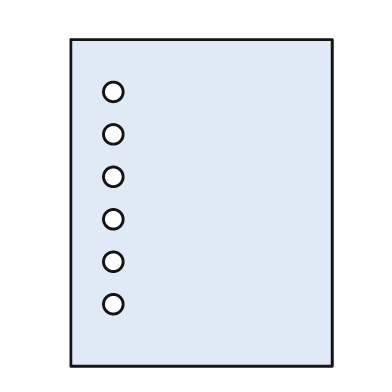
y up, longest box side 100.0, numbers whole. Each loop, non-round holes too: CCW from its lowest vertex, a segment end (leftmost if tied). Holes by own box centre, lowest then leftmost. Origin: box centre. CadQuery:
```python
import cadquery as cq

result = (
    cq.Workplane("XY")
    .moveTo(-40.0, -50.0)
    .lineTo(40.0, -50.0)
    .lineTo(40.0, 50.0)
    .lineTo(-40.0, 50.0)
    .close()
    .moveTo(-27.0, -31.0)
    .circle(3.0)
    .moveTo(-27.0, -18.0)
    .circle(3.0)
    .moveTo(-27.0, -5.0)
    .circle(3.0)
    .moveTo(-27.0, 8.0)
    .circle(3.0)
    .moveTo(-27.0, 21.0)
    .circle(3.0)
    .moveTo(-27.0, 34.0)
    .circle(3.0)
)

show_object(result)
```